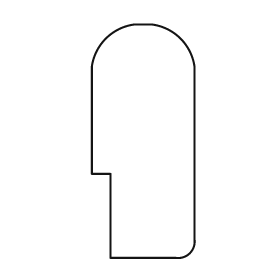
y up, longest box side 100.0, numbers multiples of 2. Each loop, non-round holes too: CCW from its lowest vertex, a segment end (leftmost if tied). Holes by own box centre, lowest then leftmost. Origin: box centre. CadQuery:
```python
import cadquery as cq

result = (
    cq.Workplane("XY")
    .moveTo(-14.0, -50.0)
    .lineTo(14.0, -50.0)
    .threePointArc((20.0, -48.0), (22.0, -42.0))
    .lineTo(22.0, 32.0)
    .threePointArc((16.0, 44.0), (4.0, 50.0))
    .lineTo(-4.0, 50.0)
    .threePointArc((-16.0, 44.0), (-22.0, 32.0))
    .lineTo(-22.0, -14.0)
    .lineTo(-14.0, -14.0)
    .close()
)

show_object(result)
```